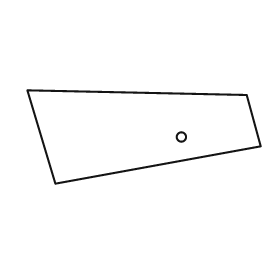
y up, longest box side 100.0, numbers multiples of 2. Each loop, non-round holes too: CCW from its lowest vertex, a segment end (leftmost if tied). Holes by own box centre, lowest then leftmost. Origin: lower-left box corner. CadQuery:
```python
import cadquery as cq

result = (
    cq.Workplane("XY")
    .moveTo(12.0, 0.0)
    .lineTo(100.0, 16.0)
    .lineTo(94.0, 38.0)
    .lineTo(0.0, 40.0)
    .close()
    .moveTo(66.0, 20.0)
    .circle(2.0)
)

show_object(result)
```